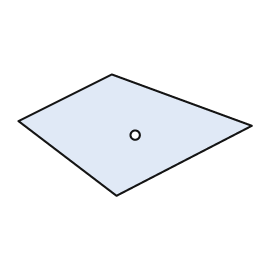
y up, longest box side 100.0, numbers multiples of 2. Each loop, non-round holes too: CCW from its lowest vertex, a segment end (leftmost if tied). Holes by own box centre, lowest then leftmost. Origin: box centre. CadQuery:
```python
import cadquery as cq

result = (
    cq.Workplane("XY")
    .moveTo(-8.0, -26.0)
    .lineTo(50.0, 4.0)
    .lineTo(-10.0, 26.0)
    .lineTo(-50.0, 6.0)
    .close()
    .moveTo(0.0, 0.0)
    .circle(2.0)
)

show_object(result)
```